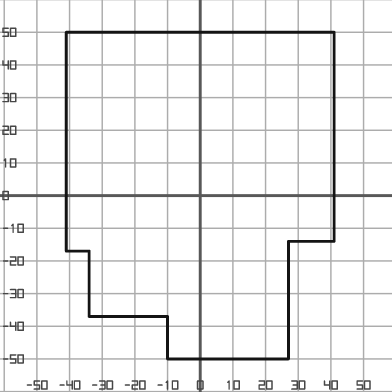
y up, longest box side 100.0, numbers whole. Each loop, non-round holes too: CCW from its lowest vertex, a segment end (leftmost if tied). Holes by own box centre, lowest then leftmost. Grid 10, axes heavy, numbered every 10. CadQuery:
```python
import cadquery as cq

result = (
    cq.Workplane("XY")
    .moveTo(-10.0, -50.0)
    .lineTo(27.0, -50.0)
    .lineTo(27.0, -14.0)
    .lineTo(41.0, -14.0)
    .lineTo(41.0, 50.0)
    .lineTo(-41.0, 50.0)
    .lineTo(-41.0, -17.0)
    .lineTo(-34.0, -17.0)
    .lineTo(-34.0, -37.0)
    .lineTo(-10.0, -37.0)
    .close()
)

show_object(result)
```